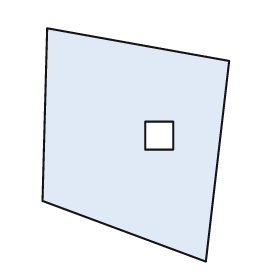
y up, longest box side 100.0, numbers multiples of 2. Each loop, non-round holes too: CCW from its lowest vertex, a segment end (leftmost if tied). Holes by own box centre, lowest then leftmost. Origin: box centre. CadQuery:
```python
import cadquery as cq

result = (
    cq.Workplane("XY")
    .moveTo(30.0, -50.0)
    .lineTo(40.0, 36.0)
    .lineTo(-38.0, 50.0)
    .lineTo(-40.0, -24.0)
    .close()
    .moveTo(4.0, -2.0)
    .lineTo(16.0, -2.0)
    .lineTo(16.0, 10.0)
    .lineTo(4.0, 10.0)
    .close()
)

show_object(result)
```